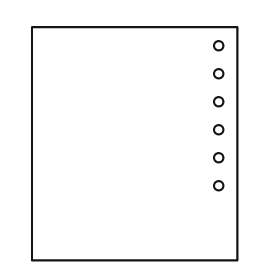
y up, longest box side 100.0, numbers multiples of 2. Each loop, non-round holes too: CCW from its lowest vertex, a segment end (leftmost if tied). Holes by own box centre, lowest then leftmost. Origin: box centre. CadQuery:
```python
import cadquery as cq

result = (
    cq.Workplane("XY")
    .moveTo(-44.0, -50.0)
    .lineTo(44.0, -50.0)
    .lineTo(44.0, 50.0)
    .lineTo(-44.0, 50.0)
    .close()
    .moveTo(36.0, -18.0)
    .circle(2.0)
    .moveTo(36.0, -6.0)
    .circle(2.0)
    .moveTo(36.0, 6.0)
    .circle(2.0)
    .moveTo(36.0, 18.0)
    .circle(2.0)
    .moveTo(36.0, 30.0)
    .circle(2.0)
    .moveTo(36.0, 42.0)
    .circle(2.0)
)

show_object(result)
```